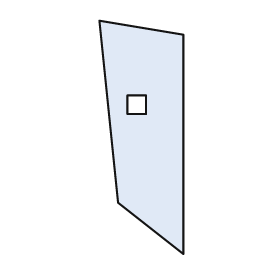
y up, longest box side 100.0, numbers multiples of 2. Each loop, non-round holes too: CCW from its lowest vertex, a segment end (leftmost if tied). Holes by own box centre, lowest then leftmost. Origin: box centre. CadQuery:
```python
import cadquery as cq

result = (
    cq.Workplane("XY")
    .moveTo(18.0, -50.0)
    .lineTo(18.0, 44.0)
    .lineTo(-18.0, 50.0)
    .lineTo(-10.0, -28.0)
    .close()
    .moveTo(-6.0, 10.0)
    .lineTo(2.0, 10.0)
    .lineTo(2.0, 18.0)
    .lineTo(-6.0, 18.0)
    .close()
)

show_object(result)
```